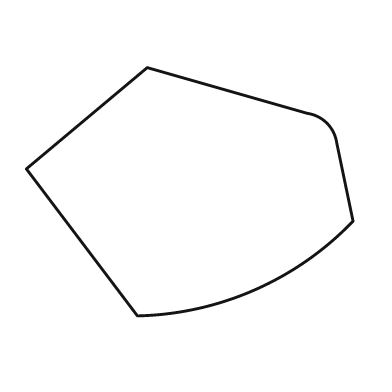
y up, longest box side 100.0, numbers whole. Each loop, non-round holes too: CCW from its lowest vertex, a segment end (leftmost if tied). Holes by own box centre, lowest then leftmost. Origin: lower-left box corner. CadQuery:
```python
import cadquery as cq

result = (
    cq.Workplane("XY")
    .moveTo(34.0, 0.0)
    .threePointArc((70.0, 8.0), (100.0, 29.0))
    .lineTo(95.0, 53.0)
    .threePointArc((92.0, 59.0), (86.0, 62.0))
    .lineTo(37.0, 76.0)
    .lineTo(0.0, 45.0)
    .close()
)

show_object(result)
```